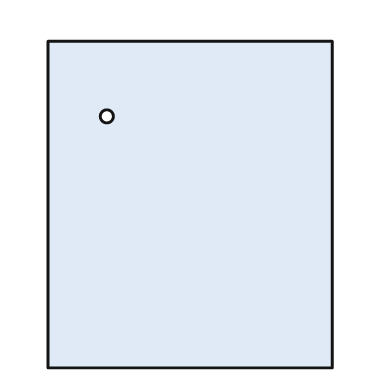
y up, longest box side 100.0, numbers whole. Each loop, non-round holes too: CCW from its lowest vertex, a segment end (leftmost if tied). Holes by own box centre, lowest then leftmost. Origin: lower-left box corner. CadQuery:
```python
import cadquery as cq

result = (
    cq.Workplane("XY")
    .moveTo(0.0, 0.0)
    .lineTo(87.0, 0.0)
    .lineTo(87.0, 100.0)
    .lineTo(0.0, 100.0)
    .close()
    .moveTo(18.0, 77.0)
    .circle(2.0)
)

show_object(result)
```